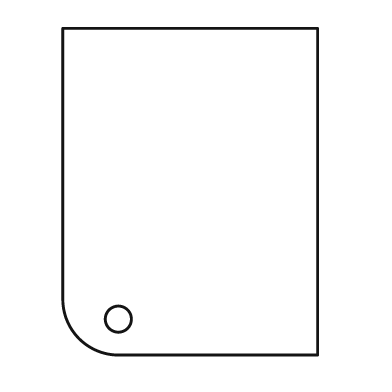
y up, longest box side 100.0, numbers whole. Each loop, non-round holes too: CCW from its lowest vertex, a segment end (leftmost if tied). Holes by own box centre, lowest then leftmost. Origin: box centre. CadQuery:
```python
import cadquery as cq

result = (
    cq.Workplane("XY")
    .moveTo(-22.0, -50.0)
    .lineTo(39.0, -50.0)
    .lineTo(39.0, 50.0)
    .lineTo(-39.0, 50.0)
    .lineTo(-39.0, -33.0)
    .threePointArc((-34.0, -45.0), (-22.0, -50.0))
    .close()
    .moveTo(-22.0, -39.0)
    .circle(4.0)
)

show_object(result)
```